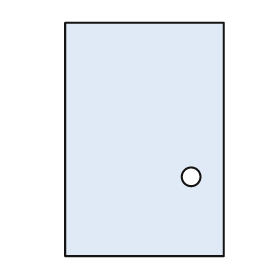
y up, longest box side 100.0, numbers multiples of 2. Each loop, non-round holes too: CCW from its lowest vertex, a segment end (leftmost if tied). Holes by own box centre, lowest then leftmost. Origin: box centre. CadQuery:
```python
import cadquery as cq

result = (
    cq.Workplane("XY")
    .moveTo(-34.0, -50.0)
    .lineTo(34.0, -50.0)
    .lineTo(34.0, 50.0)
    .lineTo(-34.0, 50.0)
    .close()
    .moveTo(20.0, -16.0)
    .circle(4.0)
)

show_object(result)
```